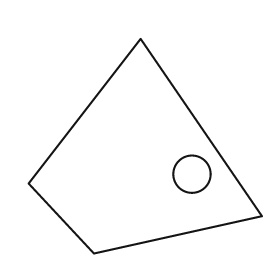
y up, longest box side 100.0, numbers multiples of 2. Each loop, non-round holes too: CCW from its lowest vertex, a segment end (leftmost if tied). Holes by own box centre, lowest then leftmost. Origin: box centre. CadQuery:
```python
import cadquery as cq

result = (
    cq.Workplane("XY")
    .moveTo(-22.0, -46.0)
    .lineTo(50.0, -30.0)
    .lineTo(-2.0, 46.0)
    .lineTo(-50.0, -16.0)
    .close()
    .moveTo(20.0, -12.0)
    .circle(8.0)
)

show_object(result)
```